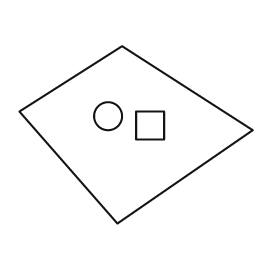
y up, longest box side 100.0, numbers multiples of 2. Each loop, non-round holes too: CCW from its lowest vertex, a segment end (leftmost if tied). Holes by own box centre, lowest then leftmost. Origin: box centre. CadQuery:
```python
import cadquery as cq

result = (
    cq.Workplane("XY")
    .moveTo(-8.0, -38.0)
    .lineTo(50.0, 2.0)
    .lineTo(-6.0, 38.0)
    .lineTo(-50.0, 10.0)
    .close()
    .moveTo(0.0, -2.0)
    .lineTo(12.0, -2.0)
    .lineTo(12.0, 10.0)
    .lineTo(0.0, 10.0)
    .close()
    .moveTo(-12.0, 8.0)
    .circle(6.0)
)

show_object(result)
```